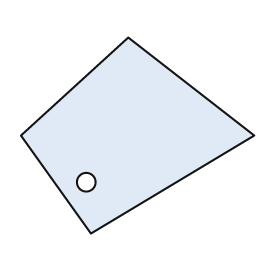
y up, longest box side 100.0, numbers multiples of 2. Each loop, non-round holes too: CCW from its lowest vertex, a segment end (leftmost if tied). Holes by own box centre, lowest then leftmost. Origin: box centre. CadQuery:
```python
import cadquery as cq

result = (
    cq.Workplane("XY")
    .moveTo(-20.0, -42.0)
    .lineTo(50.0, 0.0)
    .lineTo(-4.0, 42.0)
    .lineTo(-50.0, 0.0)
    .close()
    .moveTo(-22.0, -20.0)
    .circle(4.0)
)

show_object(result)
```